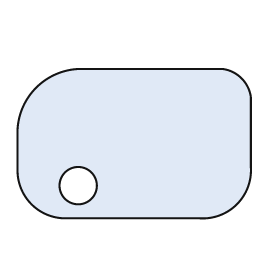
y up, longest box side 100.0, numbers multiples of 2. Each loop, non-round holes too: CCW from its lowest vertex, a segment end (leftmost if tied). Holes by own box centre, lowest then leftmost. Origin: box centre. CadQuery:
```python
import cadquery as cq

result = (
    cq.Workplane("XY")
    .moveTo(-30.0, -32.0)
    .lineTo(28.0, -32.0)
    .threePointArc((44.0, -26.0), (50.0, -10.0))
    .lineTo(50.0, 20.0)
    .threePointArc((46.0, 28.0), (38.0, 32.0))
    .lineTo(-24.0, 32.0)
    .threePointArc((-42.0, 24.0), (-50.0, 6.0))
    .lineTo(-50.0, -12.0)
    .threePointArc((-44.0, -26.0), (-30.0, -32.0))
    .close()
    .moveTo(-24.0, -18.0)
    .circle(8.0)
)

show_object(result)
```